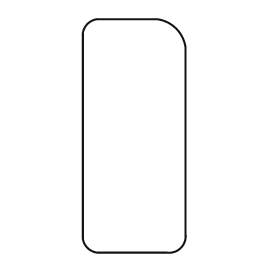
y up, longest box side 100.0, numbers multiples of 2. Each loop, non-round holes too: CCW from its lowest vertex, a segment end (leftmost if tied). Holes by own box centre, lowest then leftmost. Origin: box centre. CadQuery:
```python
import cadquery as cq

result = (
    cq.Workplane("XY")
    .moveTo(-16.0, -50.0)
    .lineTo(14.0, -50.0)
    .threePointArc((20.0, -48.0), (22.0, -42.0))
    .lineTo(22.0, 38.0)
    .threePointArc((18.0, 46.0), (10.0, 50.0))
    .lineTo(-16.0, 50.0)
    .threePointArc((-20.0, 48.0), (-22.0, 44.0))
    .lineTo(-22.0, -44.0)
    .threePointArc((-20.0, -48.0), (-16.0, -50.0))
    .close()
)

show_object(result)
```